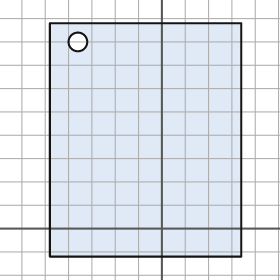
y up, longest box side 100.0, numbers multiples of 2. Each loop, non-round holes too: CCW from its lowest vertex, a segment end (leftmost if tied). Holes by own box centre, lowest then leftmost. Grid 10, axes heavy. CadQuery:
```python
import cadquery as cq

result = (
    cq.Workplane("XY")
    .moveTo(-48.0, -12.0)
    .lineTo(34.0, -12.0)
    .lineTo(34.0, 88.0)
    .lineTo(-48.0, 88.0)
    .close()
    .moveTo(-36.0, 80.0)
    .circle(4.0)
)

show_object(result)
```